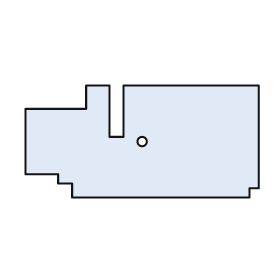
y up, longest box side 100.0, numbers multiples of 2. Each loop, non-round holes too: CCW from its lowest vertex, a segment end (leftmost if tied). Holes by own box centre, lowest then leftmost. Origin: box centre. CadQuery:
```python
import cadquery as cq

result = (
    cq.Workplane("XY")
    .moveTo(-30.0, -24.0)
    .lineTo(46.0, -24.0)
    .lineTo(46.0, -20.0)
    .lineTo(50.0, -20.0)
    .lineTo(50.0, 24.0)
    .lineTo(-8.0, 24.0)
    .lineTo(-8.0, 2.0)
    .lineTo(-14.0, 2.0)
    .lineTo(-14.0, 24.0)
    .lineTo(-24.0, 24.0)
    .lineTo(-24.0, 14.0)
    .lineTo(-50.0, 14.0)
    .lineTo(-50.0, -14.0)
    .lineTo(-36.0, -14.0)
    .lineTo(-36.0, -18.0)
    .lineTo(-30.0, -18.0)
    .close()
    .moveTo(0.0, 0.0)
    .circle(2.0)
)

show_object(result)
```